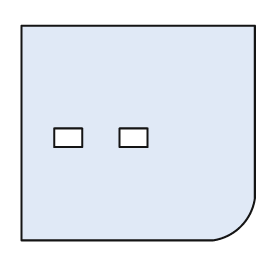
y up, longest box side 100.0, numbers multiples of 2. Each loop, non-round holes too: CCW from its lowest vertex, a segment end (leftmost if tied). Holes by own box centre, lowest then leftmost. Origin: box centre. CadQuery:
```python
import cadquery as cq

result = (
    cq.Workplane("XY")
    .moveTo(-50.0, -46.0)
    .lineTo(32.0, -46.0)
    .threePointArc((44.0, -40.0), (50.0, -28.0))
    .lineTo(50.0, 46.0)
    .lineTo(-50.0, 46.0)
    .close()
    .moveTo(-36.0, -6.0)
    .lineTo(-24.0, -6.0)
    .lineTo(-24.0, 2.0)
    .lineTo(-36.0, 2.0)
    .close()
    .moveTo(-8.0, -6.0)
    .lineTo(4.0, -6.0)
    .lineTo(4.0, 2.0)
    .lineTo(-8.0, 2.0)
    .close()
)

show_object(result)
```